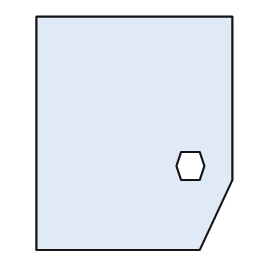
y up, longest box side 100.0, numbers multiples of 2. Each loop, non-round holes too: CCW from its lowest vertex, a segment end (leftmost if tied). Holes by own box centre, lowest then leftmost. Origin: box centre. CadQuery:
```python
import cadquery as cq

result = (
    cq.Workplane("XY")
    .moveTo(-42.0, -50.0)
    .lineTo(28.0, -50.0)
    .lineTo(42.0, -20.0)
    .lineTo(42.0, 50.0)
    .lineTo(-42.0, 50.0)
    .close()
    .moveTo(20.0, -20.0)
    .lineTo(28.0, -20.0)
    .lineTo(30.0, -14.0)
    .lineTo(28.0, -8.0)
    .lineTo(20.0, -8.0)
    .lineTo(18.0, -14.0)
    .close()
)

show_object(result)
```